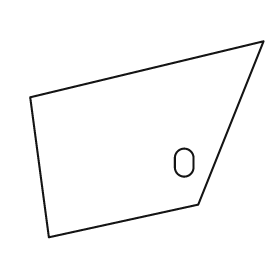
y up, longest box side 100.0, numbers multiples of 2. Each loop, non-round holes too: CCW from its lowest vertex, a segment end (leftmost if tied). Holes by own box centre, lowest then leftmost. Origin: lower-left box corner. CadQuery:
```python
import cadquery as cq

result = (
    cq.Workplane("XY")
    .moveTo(8.0, 0.0)
    .lineTo(72.0, 14.0)
    .lineTo(100.0, 84.0)
    .lineTo(0.0, 60.0)
    .close()
    .moveTo(62.0, 30.0)
    .threePointArc((66.0, 26.0), (70.0, 30.0))
    .lineTo(70.0, 34.0)
    .threePointArc((66.0, 38.0), (62.0, 34.0))
    .close()
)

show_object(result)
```